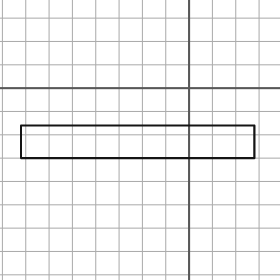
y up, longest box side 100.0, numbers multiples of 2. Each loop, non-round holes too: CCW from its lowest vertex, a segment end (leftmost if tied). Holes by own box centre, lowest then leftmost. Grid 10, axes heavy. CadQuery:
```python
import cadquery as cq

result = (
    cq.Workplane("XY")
    .moveTo(-72.0, -30.0)
    .lineTo(28.0, -30.0)
    .lineTo(28.0, -16.0)
    .lineTo(-72.0, -16.0)
    .close()
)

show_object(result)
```